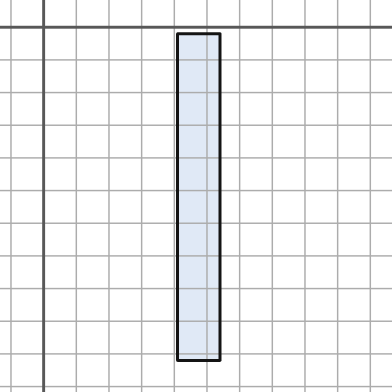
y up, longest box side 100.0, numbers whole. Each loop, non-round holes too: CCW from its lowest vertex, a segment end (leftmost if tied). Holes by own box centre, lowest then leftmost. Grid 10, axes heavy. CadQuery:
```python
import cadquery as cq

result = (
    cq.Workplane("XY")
    .moveTo(41.0, -102.0)
    .lineTo(54.0, -102.0)
    .lineTo(54.0, -2.0)
    .lineTo(41.0, -2.0)
    .close()
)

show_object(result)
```